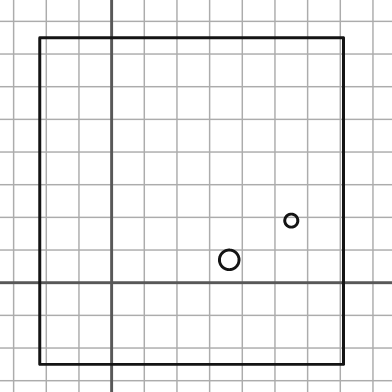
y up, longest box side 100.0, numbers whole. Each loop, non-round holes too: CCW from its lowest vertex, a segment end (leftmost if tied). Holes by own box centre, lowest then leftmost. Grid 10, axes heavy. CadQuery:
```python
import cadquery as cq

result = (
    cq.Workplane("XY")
    .moveTo(-22.0, -25.0)
    .lineTo(71.0, -25.0)
    .lineTo(71.0, 75.0)
    .lineTo(-22.0, 75.0)
    .close()
    .moveTo(36.0, 7.0)
    .circle(3.0)
    .moveTo(55.0, 19.0)
    .circle(2.0)
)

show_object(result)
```